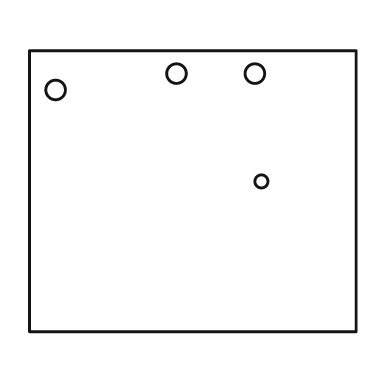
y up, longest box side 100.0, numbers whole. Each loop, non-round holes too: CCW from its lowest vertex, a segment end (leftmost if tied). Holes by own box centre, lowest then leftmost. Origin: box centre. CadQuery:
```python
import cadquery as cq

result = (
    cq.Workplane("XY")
    .moveTo(-50.0, -43.0)
    .lineTo(50.0, -43.0)
    .lineTo(50.0, 43.0)
    .lineTo(-50.0, 43.0)
    .close()
    .moveTo(21.0, 3.0)
    .circle(2.0)
    .moveTo(-42.0, 31.0)
    .circle(3.0)
    .moveTo(-5.0, 36.0)
    .circle(3.0)
    .moveTo(19.0, 36.0)
    .circle(3.0)
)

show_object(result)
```